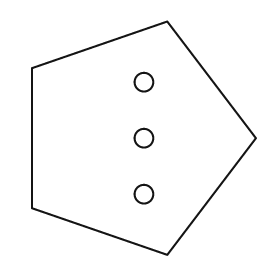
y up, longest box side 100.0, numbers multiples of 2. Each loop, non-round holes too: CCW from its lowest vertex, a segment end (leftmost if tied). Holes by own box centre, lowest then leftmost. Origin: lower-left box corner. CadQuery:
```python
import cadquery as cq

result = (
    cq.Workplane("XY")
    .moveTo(58.0, 0.0)
    .lineTo(96.0, 50.0)
    .lineTo(58.0, 100.0)
    .lineTo(0.0, 80.0)
    .lineTo(0.0, 20.0)
    .close()
    .moveTo(48.0, 26.0)
    .circle(4.0)
    .moveTo(48.0, 50.0)
    .circle(4.0)
    .moveTo(48.0, 74.0)
    .circle(4.0)
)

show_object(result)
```